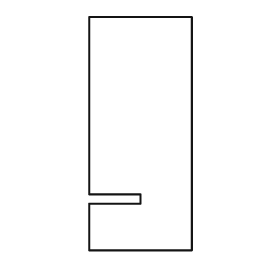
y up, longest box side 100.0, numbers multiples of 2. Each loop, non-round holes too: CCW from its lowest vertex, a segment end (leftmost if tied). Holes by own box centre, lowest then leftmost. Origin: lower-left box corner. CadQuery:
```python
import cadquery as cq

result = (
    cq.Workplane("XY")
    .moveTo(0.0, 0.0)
    .lineTo(44.0, 0.0)
    .lineTo(44.0, 100.0)
    .lineTo(0.0, 100.0)
    .lineTo(0.0, 24.0)
    .lineTo(22.0, 24.0)
    .lineTo(22.0, 20.0)
    .lineTo(0.0, 20.0)
    .close()
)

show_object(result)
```